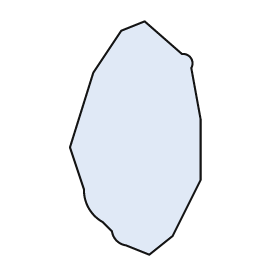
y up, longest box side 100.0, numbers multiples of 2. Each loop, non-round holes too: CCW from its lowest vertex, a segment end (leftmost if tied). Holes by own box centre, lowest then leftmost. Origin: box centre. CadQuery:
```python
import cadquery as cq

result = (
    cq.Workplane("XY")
    .moveTo(6.0, -50.0)
    .lineTo(16.0, -42.0)
    .lineTo(28.0, -18.0)
    .lineTo(28.0, 8.0)
    .lineTo(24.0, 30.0)
    .threePointArc((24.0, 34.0), (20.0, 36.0))
    .lineTo(4.0, 50.0)
    .lineTo(-6.0, 46.0)
    .lineTo(-18.0, 28.0)
    .lineTo(-28.0, -4.0)
    .lineTo(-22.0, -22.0)
    .threePointArc((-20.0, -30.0), (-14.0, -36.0))
    .lineTo(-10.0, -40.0)
    .threePointArc((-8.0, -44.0), (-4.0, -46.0))
    .close()
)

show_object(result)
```